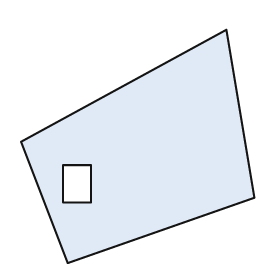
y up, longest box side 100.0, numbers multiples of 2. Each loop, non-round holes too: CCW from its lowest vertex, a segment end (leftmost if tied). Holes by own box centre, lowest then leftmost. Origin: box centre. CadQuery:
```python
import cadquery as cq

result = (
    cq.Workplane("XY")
    .moveTo(-30.0, -50.0)
    .lineTo(50.0, -22.0)
    .lineTo(38.0, 50.0)
    .lineTo(-50.0, 2.0)
    .close()
    .moveTo(-32.0, -24.0)
    .lineTo(-20.0, -24.0)
    .lineTo(-20.0, -8.0)
    .lineTo(-32.0, -8.0)
    .close()
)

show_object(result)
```